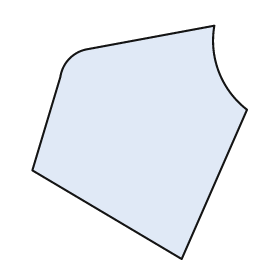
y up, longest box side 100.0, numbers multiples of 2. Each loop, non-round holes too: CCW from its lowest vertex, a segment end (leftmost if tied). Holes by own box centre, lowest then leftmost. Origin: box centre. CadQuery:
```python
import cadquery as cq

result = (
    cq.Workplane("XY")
    .moveTo(18.0, -50.0)
    .lineTo(46.0, 14.0)
    .threePointArc((34.0, 30.0), (32.0, 50.0))
    .lineTo(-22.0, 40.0)
    .threePointArc((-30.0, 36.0), (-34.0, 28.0))
    .lineTo(-46.0, -12.0)
    .close()
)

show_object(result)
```